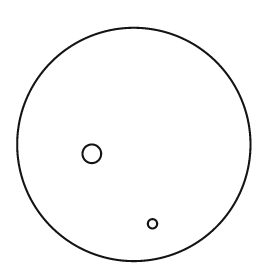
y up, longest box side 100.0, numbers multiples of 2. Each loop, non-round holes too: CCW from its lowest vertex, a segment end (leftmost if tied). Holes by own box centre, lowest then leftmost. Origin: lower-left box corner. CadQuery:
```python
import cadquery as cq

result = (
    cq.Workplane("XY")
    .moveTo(50.0, 50.0)
    .circle(50.0)
    .moveTo(58.0, 16.0)
    .circle(2.0)
    .moveTo(32.0, 46.0)
    .circle(4.0)
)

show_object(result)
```